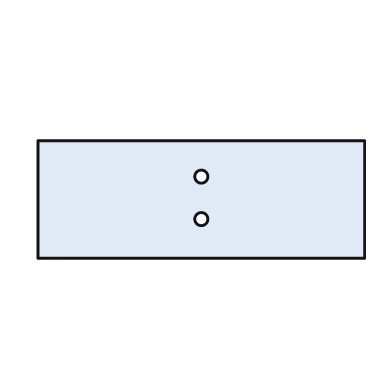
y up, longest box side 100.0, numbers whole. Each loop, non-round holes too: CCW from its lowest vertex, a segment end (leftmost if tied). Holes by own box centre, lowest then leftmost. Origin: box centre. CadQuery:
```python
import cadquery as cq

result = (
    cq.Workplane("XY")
    .moveTo(-50.0, -18.0)
    .lineTo(50.0, -18.0)
    .lineTo(50.0, 18.0)
    .lineTo(-50.0, 18.0)
    .close()
    .moveTo(0.0, -6.0)
    .circle(2.0)
    .moveTo(0.0, 7.0)
    .circle(2.0)
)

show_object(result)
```